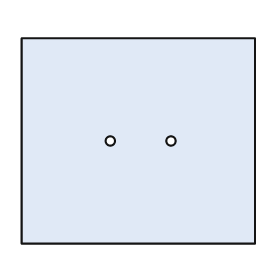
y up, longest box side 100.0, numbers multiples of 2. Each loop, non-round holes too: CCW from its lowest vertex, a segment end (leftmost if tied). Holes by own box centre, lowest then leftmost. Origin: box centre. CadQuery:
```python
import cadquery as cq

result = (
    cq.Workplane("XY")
    .moveTo(-50.0, -44.0)
    .lineTo(50.0, -44.0)
    .lineTo(50.0, 44.0)
    .lineTo(-50.0, 44.0)
    .close()
    .moveTo(-12.0, 0.0)
    .circle(2.0)
    .moveTo(14.0, 0.0)
    .circle(2.0)
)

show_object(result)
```